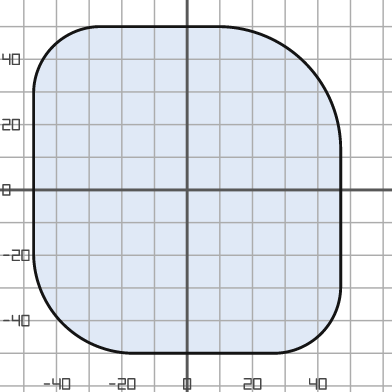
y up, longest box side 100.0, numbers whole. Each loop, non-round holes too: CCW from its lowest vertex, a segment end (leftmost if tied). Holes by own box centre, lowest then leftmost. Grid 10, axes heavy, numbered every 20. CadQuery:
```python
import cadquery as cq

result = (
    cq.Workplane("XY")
    .moveTo(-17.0, -50.0)
    .lineTo(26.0, -50.0)
    .threePointArc((41.0, -44.0), (47.0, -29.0))
    .lineTo(47.0, 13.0)
    .threePointArc((36.0, 39.0), (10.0, 50.0))
    .lineTo(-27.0, 50.0)
    .threePointArc((-41.0, 44.0), (-47.0, 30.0))
    .lineTo(-47.0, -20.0)
    .threePointArc((-38.0, -41.0), (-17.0, -50.0))
    .close()
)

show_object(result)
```